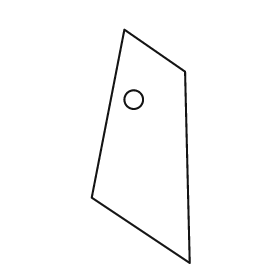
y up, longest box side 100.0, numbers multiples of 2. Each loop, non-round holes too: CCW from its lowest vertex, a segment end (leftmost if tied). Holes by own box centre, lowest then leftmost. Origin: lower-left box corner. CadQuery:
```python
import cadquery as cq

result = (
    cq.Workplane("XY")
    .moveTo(42.0, 0.0)
    .lineTo(40.0, 82.0)
    .lineTo(14.0, 100.0)
    .lineTo(0.0, 28.0)
    .close()
    .moveTo(18.0, 70.0)
    .circle(4.0)
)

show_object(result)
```